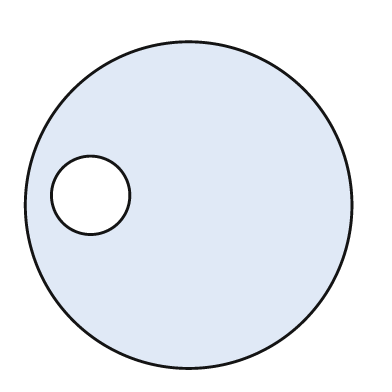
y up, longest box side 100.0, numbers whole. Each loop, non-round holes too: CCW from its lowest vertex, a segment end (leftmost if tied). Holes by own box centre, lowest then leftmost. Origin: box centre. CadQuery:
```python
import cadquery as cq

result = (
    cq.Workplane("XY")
    .moveTo(0.0, 0.0)
    .circle(50.0)
    .moveTo(-30.0, 3.0)
    .circle(12.0)
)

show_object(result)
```